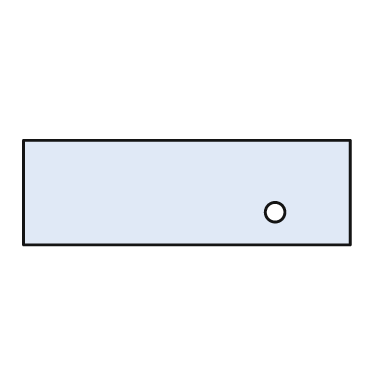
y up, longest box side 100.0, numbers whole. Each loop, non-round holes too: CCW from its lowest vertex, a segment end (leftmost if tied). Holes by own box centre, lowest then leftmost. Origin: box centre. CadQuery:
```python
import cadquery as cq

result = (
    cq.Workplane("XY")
    .moveTo(-50.0, -16.0)
    .lineTo(50.0, -16.0)
    .lineTo(50.0, 16.0)
    .lineTo(-50.0, 16.0)
    .close()
    .moveTo(27.0, -6.0)
    .circle(3.0)
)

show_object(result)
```